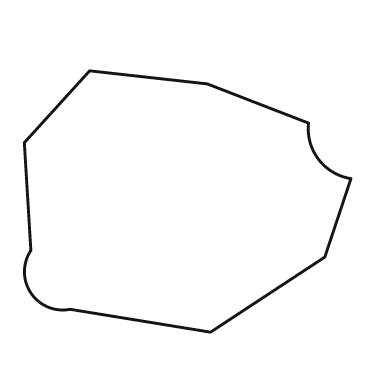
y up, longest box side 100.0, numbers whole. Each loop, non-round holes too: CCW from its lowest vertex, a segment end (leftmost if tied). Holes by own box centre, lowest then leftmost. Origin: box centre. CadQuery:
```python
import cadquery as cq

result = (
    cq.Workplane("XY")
    .moveTo(7.0, -40.0)
    .lineTo(42.0, -17.0)
    .lineTo(50.0, 7.0)
    .threePointArc((40.0, 13.0), (37.0, 24.0))
    .lineTo(6.0, 36.0)
    .lineTo(-30.0, 40.0)
    .lineTo(-50.0, 18.0)
    .lineTo(-48.0, -15.0)
    .threePointArc((-48.0, -28.0), (-36.0, -33.0))
    .close()
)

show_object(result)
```